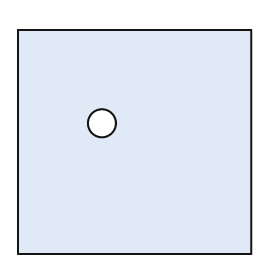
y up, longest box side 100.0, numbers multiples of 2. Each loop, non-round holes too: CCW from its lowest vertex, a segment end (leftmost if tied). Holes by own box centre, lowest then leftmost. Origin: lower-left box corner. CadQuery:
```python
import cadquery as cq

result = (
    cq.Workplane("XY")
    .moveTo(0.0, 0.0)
    .lineTo(100.0, 0.0)
    .lineTo(100.0, 96.0)
    .lineTo(0.0, 96.0)
    .close()
    .moveTo(36.0, 56.0)
    .circle(6.0)
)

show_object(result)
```